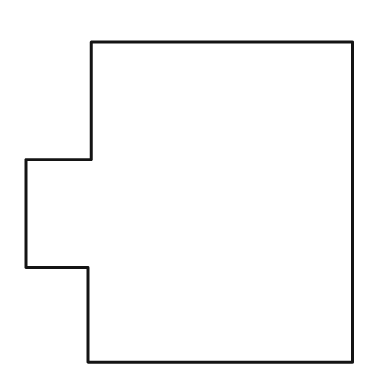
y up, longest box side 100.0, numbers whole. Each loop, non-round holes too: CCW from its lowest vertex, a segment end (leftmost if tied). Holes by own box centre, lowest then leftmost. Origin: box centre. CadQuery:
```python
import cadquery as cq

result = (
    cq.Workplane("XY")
    .moveTo(-31.0, -49.0)
    .lineTo(50.0, -49.0)
    .lineTo(50.0, 49.0)
    .lineTo(-30.0, 49.0)
    .lineTo(-30.0, 13.0)
    .lineTo(-50.0, 13.0)
    .lineTo(-50.0, -20.0)
    .lineTo(-31.0, -20.0)
    .close()
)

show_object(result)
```